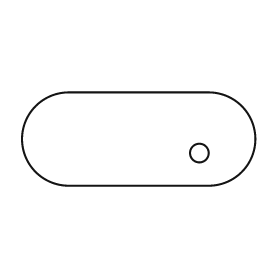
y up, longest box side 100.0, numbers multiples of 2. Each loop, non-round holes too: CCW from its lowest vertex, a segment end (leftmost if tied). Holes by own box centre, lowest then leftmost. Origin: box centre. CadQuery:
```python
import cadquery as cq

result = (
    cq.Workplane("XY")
    .moveTo(-30.0, -20.0)
    .lineTo(30.0, -20.0)
    .threePointArc((50.0, 0.0), (30.0, 20.0))
    .lineTo(-30.0, 20.0)
    .threePointArc((-50.0, 0.0), (-30.0, -20.0))
    .close()
    .moveTo(26.0, -6.0)
    .circle(4.0)
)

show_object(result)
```